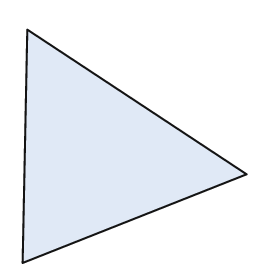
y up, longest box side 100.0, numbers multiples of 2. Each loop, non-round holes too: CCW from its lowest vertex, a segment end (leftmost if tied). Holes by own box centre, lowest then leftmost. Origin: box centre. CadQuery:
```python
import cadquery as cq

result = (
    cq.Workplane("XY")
    .moveTo(-48.0, -50.0)
    .lineTo(48.0, -12.0)
    .lineTo(-46.0, 50.0)
    .close()
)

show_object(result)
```